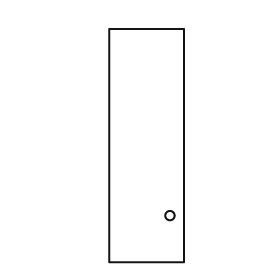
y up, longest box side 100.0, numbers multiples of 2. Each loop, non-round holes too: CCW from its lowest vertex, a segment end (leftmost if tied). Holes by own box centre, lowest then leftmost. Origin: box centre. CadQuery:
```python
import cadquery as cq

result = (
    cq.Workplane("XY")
    .moveTo(-16.0, -50.0)
    .lineTo(16.0, -50.0)
    .lineTo(16.0, 50.0)
    .lineTo(-16.0, 50.0)
    .close()
    .moveTo(10.0, -30.0)
    .circle(2.0)
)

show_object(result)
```